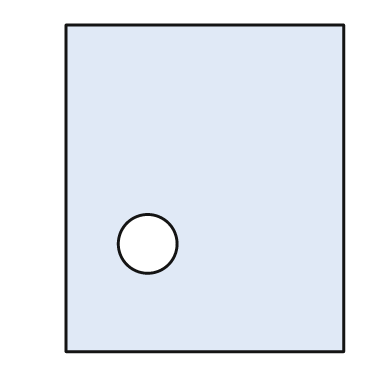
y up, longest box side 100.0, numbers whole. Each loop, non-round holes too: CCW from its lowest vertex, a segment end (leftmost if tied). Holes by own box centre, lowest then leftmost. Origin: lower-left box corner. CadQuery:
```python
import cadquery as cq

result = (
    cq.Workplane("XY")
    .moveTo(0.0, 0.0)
    .lineTo(85.0, 0.0)
    .lineTo(85.0, 100.0)
    .lineTo(0.0, 100.0)
    .close()
    .moveTo(25.0, 33.0)
    .circle(9.0)
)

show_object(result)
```